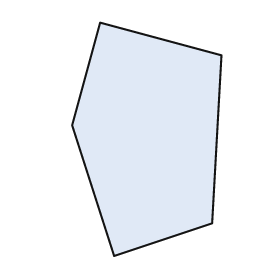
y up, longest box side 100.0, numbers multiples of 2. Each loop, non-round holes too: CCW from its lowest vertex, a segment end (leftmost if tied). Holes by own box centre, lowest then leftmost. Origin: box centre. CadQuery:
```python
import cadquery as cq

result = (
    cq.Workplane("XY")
    .moveTo(-14.0, -50.0)
    .lineTo(28.0, -36.0)
    .lineTo(32.0, 36.0)
    .lineTo(-20.0, 50.0)
    .lineTo(-32.0, 6.0)
    .close()
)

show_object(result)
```